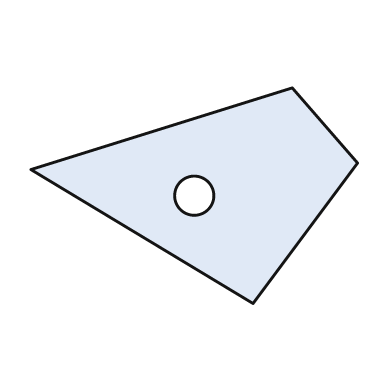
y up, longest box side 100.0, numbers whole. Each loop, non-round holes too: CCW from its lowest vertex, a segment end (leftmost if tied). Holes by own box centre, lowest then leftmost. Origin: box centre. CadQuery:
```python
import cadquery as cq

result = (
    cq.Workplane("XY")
    .moveTo(18.0, -33.0)
    .lineTo(50.0, 10.0)
    .lineTo(30.0, 33.0)
    .lineTo(-50.0, 8.0)
    .close()
    .moveTo(0.0, 0.0)
    .circle(6.0)
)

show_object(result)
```